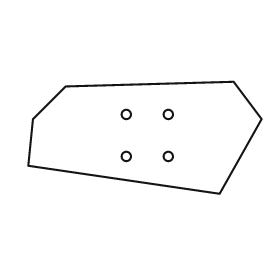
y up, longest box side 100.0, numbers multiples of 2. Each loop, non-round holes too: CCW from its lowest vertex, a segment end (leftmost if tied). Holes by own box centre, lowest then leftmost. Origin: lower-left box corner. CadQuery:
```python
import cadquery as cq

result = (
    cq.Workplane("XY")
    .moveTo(82.0, 0.0)
    .lineTo(100.0, 32.0)
    .lineTo(88.0, 48.0)
    .lineTo(16.0, 46.0)
    .lineTo(2.0, 32.0)
    .lineTo(0.0, 12.0)
    .close()
    .moveTo(42.0, 16.0)
    .circle(2.0)
    .moveTo(60.0, 16.0)
    .circle(2.0)
    .moveTo(42.0, 34.0)
    .circle(2.0)
    .moveTo(60.0, 34.0)
    .circle(2.0)
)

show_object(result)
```